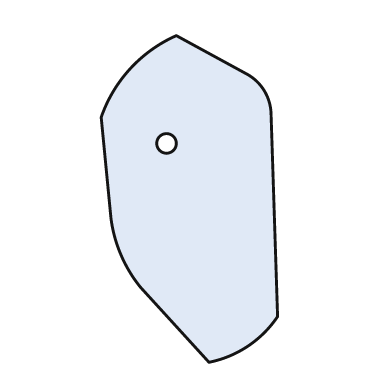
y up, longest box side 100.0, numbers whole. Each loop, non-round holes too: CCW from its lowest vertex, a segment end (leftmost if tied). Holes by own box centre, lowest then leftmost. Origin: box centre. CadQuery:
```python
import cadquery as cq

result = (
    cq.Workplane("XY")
    .moveTo(6.0, -50.0)
    .threePointArc((18.0, -45.0), (27.0, -36.0))
    .lineTo(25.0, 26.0)
    .threePointArc((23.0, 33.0), (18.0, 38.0))
    .lineTo(-4.0, 50.0)
    .threePointArc((-18.0, 40.0), (-27.0, 25.0))
    .lineTo(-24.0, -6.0)
    .threePointArc((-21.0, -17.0), (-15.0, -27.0))
    .close()
    .moveTo(-7.0, 17.0)
    .circle(3.0)
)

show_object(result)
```